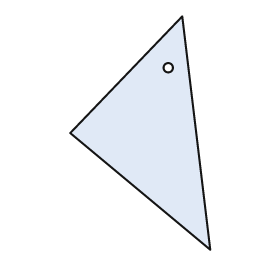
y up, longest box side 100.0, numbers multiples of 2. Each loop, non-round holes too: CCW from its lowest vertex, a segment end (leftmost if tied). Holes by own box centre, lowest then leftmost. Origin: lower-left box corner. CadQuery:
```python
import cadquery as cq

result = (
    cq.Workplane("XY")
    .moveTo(60.0, 0.0)
    .lineTo(48.0, 100.0)
    .lineTo(0.0, 50.0)
    .close()
    .moveTo(42.0, 78.0)
    .circle(2.0)
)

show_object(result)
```